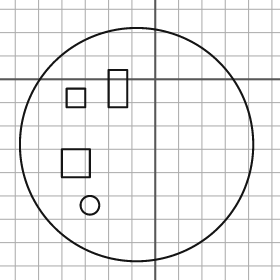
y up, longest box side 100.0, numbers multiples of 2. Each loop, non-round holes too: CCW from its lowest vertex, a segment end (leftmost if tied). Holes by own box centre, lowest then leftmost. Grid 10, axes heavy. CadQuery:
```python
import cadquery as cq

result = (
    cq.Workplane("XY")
    .moveTo(-8.0, -28.0)
    .circle(50.0)
    .moveTo(-28.0, -54.0)
    .circle(4.0)
    .moveTo(-40.0, -42.0)
    .lineTo(-28.0, -42.0)
    .lineTo(-28.0, -30.0)
    .lineTo(-40.0, -30.0)
    .close()
    .moveTo(-38.0, -12.0)
    .lineTo(-30.0, -12.0)
    .lineTo(-30.0, -4.0)
    .lineTo(-38.0, -4.0)
    .close()
    .moveTo(-20.0, -12.0)
    .lineTo(-12.0, -12.0)
    .lineTo(-12.0, 4.0)
    .lineTo(-20.0, 4.0)
    .close()
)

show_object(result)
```